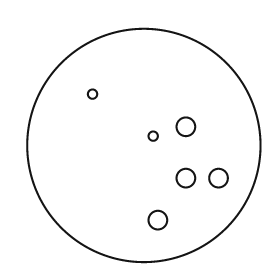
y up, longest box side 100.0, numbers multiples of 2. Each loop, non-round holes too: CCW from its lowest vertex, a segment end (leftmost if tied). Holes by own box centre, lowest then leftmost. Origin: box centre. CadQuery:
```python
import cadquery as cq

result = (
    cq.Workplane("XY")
    .moveTo(0.0, 0.0)
    .circle(50.0)
    .moveTo(6.0, -32.0)
    .circle(4.0)
    .moveTo(18.0, -14.0)
    .circle(4.0)
    .moveTo(32.0, -14.0)
    .circle(4.0)
    .moveTo(4.0, 4.0)
    .circle(2.0)
    .moveTo(18.0, 8.0)
    .circle(4.0)
    .moveTo(-22.0, 22.0)
    .circle(2.0)
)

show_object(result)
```